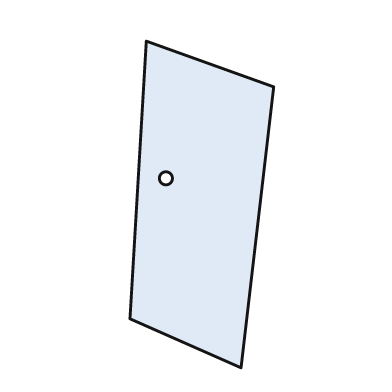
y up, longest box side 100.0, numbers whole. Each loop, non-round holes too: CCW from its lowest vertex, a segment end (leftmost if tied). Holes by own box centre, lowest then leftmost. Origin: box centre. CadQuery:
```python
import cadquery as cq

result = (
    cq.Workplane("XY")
    .moveTo(12.0, -50.0)
    .lineTo(22.0, 36.0)
    .lineTo(-17.0, 50.0)
    .lineTo(-22.0, -35.0)
    .close()
    .moveTo(-11.0, 8.0)
    .circle(2.0)
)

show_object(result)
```